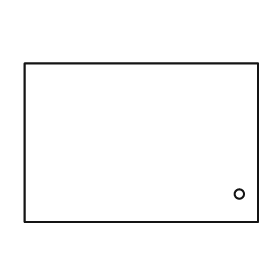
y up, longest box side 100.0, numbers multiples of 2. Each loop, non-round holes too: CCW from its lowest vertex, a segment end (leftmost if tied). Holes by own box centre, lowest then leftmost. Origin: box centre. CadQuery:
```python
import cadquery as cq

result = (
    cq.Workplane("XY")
    .moveTo(-50.0, -34.0)
    .lineTo(50.0, -34.0)
    .lineTo(50.0, 34.0)
    .lineTo(-50.0, 34.0)
    .close()
    .moveTo(42.0, -22.0)
    .circle(2.0)
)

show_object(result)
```